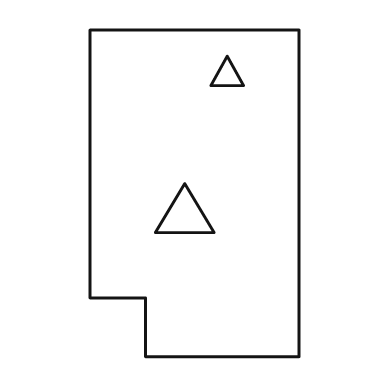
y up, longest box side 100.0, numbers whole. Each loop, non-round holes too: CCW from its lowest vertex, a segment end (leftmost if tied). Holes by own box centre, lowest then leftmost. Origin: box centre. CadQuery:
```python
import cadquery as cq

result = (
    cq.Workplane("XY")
    .moveTo(-15.0, -50.0)
    .lineTo(32.0, -50.0)
    .lineTo(32.0, 50.0)
    .lineTo(-32.0, 50.0)
    .lineTo(-32.0, -32.0)
    .lineTo(-15.0, -32.0)
    .close()
    .moveTo(-12.0, -12.0)
    .lineTo(6.0, -12.0)
    .lineTo(-3.0, 3.0)
    .close()
    .moveTo(5.0, 33.0)
    .lineTo(15.0, 33.0)
    .lineTo(10.0, 42.0)
    .close()
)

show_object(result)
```